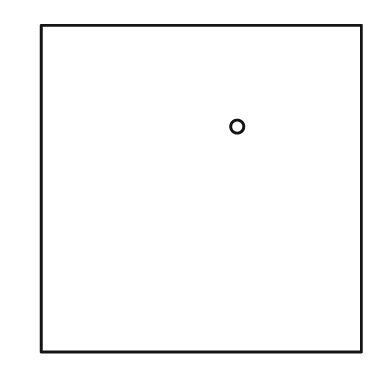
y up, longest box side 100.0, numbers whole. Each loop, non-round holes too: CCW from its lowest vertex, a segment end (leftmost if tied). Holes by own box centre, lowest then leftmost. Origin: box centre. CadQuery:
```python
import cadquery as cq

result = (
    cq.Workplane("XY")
    .moveTo(-49.0, -50.0)
    .lineTo(49.0, -50.0)
    .lineTo(49.0, 50.0)
    .lineTo(-49.0, 50.0)
    .close()
    .moveTo(11.0, 19.0)
    .circle(2.0)
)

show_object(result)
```